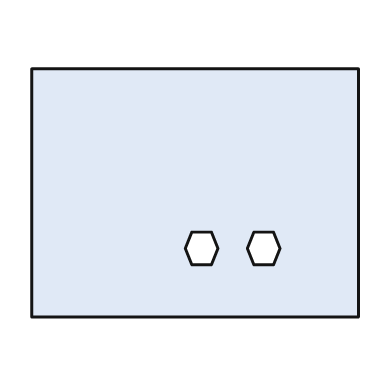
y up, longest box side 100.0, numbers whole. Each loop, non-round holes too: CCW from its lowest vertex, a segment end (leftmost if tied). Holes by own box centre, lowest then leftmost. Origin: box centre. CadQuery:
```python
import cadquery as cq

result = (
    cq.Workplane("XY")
    .moveTo(-50.0, -38.0)
    .lineTo(50.0, -38.0)
    .lineTo(50.0, 38.0)
    .lineTo(-50.0, 38.0)
    .close()
    .moveTo(-1.0, -22.0)
    .lineTo(5.0, -22.0)
    .lineTo(7.0, -17.0)
    .lineTo(5.0, -12.0)
    .lineTo(-1.0, -12.0)
    .lineTo(-3.0, -17.0)
    .close()
    .moveTo(18.0, -22.0)
    .lineTo(24.0, -22.0)
    .lineTo(26.0, -17.0)
    .lineTo(24.0, -12.0)
    .lineTo(18.0, -12.0)
    .lineTo(16.0, -17.0)
    .close()
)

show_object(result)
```